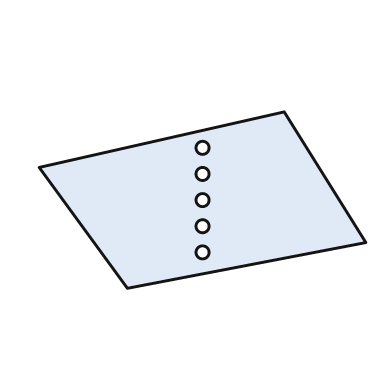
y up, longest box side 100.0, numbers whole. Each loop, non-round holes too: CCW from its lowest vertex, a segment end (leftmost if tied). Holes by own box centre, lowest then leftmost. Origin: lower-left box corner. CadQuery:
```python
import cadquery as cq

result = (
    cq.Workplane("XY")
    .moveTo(27.0, 0.0)
    .lineTo(100.0, 14.0)
    .lineTo(75.0, 54.0)
    .lineTo(0.0, 37.0)
    .close()
    .moveTo(50.0, 11.0)
    .circle(2.0)
    .moveTo(50.0, 19.0)
    .circle(2.0)
    .moveTo(50.0, 27.0)
    .circle(2.0)
    .moveTo(50.0, 35.0)
    .circle(2.0)
    .moveTo(50.0, 43.0)
    .circle(2.0)
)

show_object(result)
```